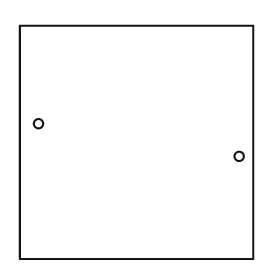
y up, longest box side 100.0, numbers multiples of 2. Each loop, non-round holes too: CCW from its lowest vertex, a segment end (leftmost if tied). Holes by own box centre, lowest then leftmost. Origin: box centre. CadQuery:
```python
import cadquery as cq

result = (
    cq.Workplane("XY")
    .moveTo(-50.0, -50.0)
    .lineTo(50.0, -50.0)
    .lineTo(50.0, 50.0)
    .lineTo(-50.0, 50.0)
    .close()
    .moveTo(44.0, -6.0)
    .circle(2.0)
    .moveTo(-42.0, 8.0)
    .circle(2.0)
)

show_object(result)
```